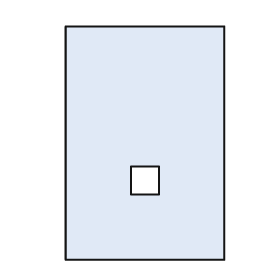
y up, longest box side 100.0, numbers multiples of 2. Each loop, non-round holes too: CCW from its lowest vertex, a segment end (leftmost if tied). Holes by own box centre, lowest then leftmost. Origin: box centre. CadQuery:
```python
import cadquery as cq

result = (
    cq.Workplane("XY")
    .moveTo(-34.0, -50.0)
    .lineTo(34.0, -50.0)
    .lineTo(34.0, 50.0)
    .lineTo(-34.0, 50.0)
    .close()
    .moveTo(-6.0, -22.0)
    .lineTo(6.0, -22.0)
    .lineTo(6.0, -10.0)
    .lineTo(-6.0, -10.0)
    .close()
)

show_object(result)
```